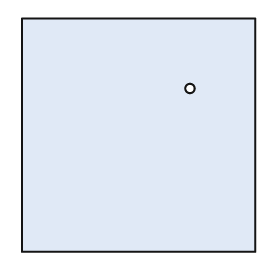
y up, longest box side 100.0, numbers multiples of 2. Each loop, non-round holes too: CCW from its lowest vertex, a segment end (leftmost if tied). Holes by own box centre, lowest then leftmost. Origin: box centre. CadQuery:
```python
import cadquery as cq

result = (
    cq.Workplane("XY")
    .moveTo(-50.0, -50.0)
    .lineTo(50.0, -50.0)
    .lineTo(50.0, 50.0)
    .lineTo(-50.0, 50.0)
    .close()
    .moveTo(22.0, 20.0)
    .circle(2.0)
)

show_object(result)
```